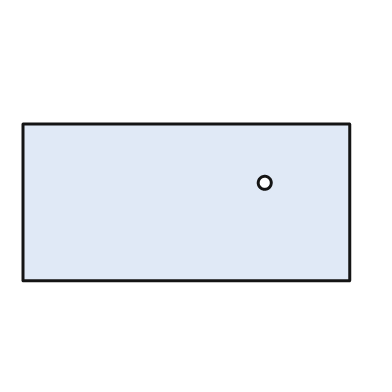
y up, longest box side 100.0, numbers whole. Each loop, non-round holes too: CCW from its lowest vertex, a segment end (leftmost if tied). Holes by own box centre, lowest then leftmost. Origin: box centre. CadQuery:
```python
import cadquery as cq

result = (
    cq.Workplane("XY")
    .moveTo(-50.0, -24.0)
    .lineTo(50.0, -24.0)
    .lineTo(50.0, 24.0)
    .lineTo(-50.0, 24.0)
    .close()
    .moveTo(24.0, 6.0)
    .circle(2.0)
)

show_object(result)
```